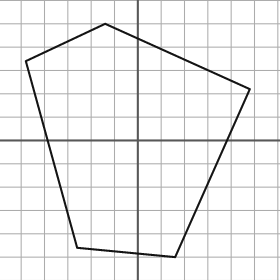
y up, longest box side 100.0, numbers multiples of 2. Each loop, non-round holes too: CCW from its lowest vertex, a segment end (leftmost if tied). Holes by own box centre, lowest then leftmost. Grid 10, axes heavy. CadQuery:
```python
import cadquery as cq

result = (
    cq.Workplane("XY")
    .moveTo(16.0, -50.0)
    .lineTo(48.0, 22.0)
    .lineTo(-14.0, 50.0)
    .lineTo(-48.0, 34.0)
    .lineTo(-26.0, -46.0)
    .close()
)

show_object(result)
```